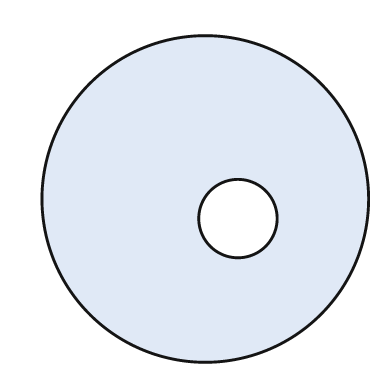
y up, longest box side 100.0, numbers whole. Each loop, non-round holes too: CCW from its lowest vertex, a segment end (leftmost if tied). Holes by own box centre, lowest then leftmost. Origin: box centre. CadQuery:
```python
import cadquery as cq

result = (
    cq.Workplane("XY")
    .moveTo(0.0, 0.0)
    .circle(50.0)
    .moveTo(10.0, -6.0)
    .circle(12.0)
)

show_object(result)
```